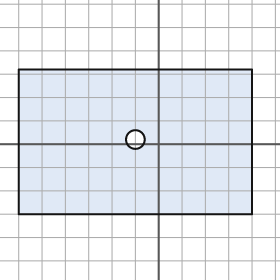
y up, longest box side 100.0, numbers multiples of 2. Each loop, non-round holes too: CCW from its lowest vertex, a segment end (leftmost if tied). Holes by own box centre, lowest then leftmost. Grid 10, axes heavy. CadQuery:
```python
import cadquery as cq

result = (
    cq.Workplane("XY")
    .moveTo(-60.0, -30.0)
    .lineTo(40.0, -30.0)
    .lineTo(40.0, 32.0)
    .lineTo(-60.0, 32.0)
    .close()
    .moveTo(-10.0, 2.0)
    .circle(4.0)
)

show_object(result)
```